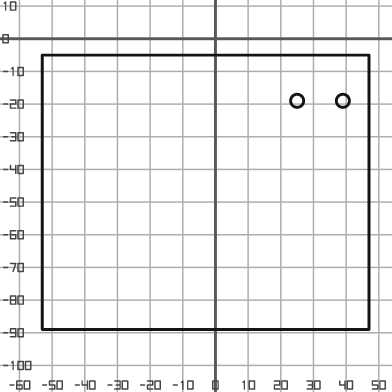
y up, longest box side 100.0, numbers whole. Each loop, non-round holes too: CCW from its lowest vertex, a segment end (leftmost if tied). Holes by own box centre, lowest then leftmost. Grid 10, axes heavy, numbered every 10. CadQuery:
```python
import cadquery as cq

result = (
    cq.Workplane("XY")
    .moveTo(-53.0, -89.0)
    .lineTo(47.0, -89.0)
    .lineTo(47.0, -5.0)
    .lineTo(-53.0, -5.0)
    .close()
    .moveTo(25.0, -19.0)
    .circle(2.0)
    .moveTo(39.0, -19.0)
    .circle(2.0)
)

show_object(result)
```